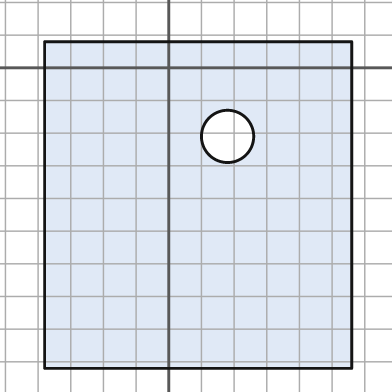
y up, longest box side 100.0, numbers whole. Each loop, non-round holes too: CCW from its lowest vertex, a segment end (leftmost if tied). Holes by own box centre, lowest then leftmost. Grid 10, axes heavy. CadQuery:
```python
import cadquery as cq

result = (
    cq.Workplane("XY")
    .moveTo(-38.0, -92.0)
    .lineTo(56.0, -92.0)
    .lineTo(56.0, 8.0)
    .lineTo(-38.0, 8.0)
    .close()
    .moveTo(18.0, -21.0)
    .circle(8.0)
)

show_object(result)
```